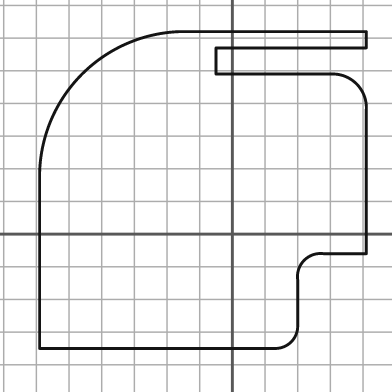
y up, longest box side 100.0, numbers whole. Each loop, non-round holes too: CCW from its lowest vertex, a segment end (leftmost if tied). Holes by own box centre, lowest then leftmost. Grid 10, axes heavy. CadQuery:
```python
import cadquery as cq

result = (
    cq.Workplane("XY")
    .moveTo(-59.0, -35.0)
    .lineTo(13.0, -35.0)
    .threePointArc((18.0, -33.0), (20.0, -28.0))
    .lineTo(20.0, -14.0)
    .threePointArc((22.0, -8.0), (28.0, -6.0))
    .lineTo(41.0, -6.0)
    .lineTo(41.0, 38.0)
    .threePointArc((38.0, 46.0), (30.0, 49.0))
    .lineTo(-5.0, 49.0)
    .lineTo(-5.0, 57.0)
    .lineTo(41.0, 57.0)
    .lineTo(41.0, 62.0)
    .lineTo(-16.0, 62.0)
    .threePointArc((-46.0, 49.0), (-59.0, 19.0))
    .close()
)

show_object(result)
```